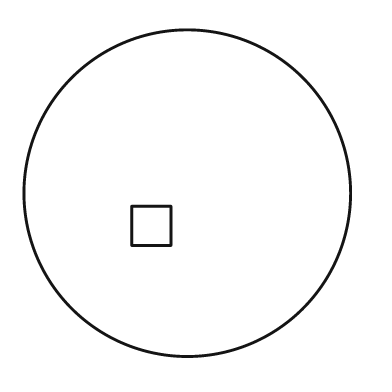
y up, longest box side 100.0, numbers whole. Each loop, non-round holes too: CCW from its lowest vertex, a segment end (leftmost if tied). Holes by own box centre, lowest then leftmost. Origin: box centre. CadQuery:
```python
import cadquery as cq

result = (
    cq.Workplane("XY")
    .moveTo(0.0, 0.0)
    .circle(50.0)
    .moveTo(-17.0, -16.0)
    .lineTo(-5.0, -16.0)
    .lineTo(-5.0, -4.0)
    .lineTo(-17.0, -4.0)
    .close()
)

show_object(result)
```